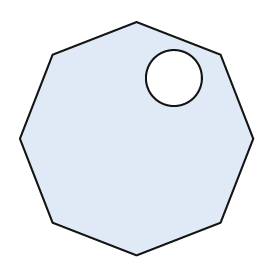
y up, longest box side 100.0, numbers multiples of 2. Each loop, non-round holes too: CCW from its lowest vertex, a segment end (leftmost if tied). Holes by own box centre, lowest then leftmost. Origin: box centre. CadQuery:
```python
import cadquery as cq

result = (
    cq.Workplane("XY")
    .moveTo(0.0, -50.0)
    .lineTo(36.0, -36.0)
    .lineTo(50.0, 0.0)
    .lineTo(36.0, 36.0)
    .lineTo(0.0, 50.0)
    .lineTo(-36.0, 36.0)
    .lineTo(-50.0, 0.0)
    .lineTo(-36.0, -36.0)
    .close()
    .moveTo(16.0, 26.0)
    .circle(12.0)
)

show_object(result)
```